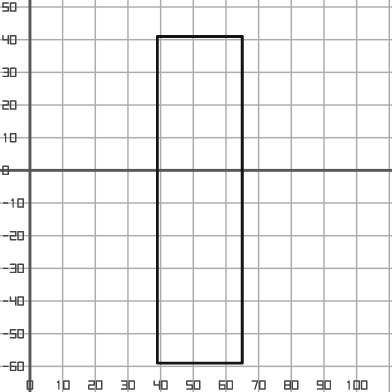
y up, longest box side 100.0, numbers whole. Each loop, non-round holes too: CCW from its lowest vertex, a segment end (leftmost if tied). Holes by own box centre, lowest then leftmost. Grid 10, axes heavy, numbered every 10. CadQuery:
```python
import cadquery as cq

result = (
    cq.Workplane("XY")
    .moveTo(39.0, -59.0)
    .lineTo(65.0, -59.0)
    .lineTo(65.0, 41.0)
    .lineTo(39.0, 41.0)
    .close()
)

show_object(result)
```